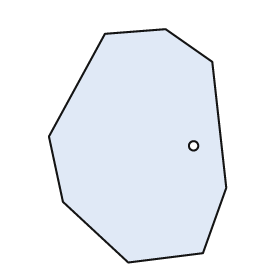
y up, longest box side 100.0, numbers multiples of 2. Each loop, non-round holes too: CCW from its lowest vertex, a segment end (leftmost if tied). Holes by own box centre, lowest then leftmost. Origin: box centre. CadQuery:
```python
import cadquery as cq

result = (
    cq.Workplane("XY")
    .moveTo(-4.0, -50.0)
    .lineTo(28.0, -46.0)
    .lineTo(38.0, -18.0)
    .lineTo(32.0, 36.0)
    .lineTo(12.0, 50.0)
    .lineTo(-14.0, 48.0)
    .lineTo(-38.0, 4.0)
    .lineTo(-32.0, -24.0)
    .close()
    .moveTo(24.0, 0.0)
    .circle(2.0)
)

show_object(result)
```